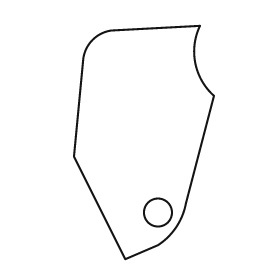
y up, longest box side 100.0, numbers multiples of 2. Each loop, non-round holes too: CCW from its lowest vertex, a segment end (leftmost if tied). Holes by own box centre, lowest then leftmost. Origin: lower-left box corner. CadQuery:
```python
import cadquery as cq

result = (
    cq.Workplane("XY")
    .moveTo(22.0, 0.0)
    .lineTo(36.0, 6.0)
    .threePointArc((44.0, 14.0), (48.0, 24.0))
    .lineTo(60.0, 70.0)
    .threePointArc((52.0, 84.0), (54.0, 100.0))
    .lineTo(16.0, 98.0)
    .threePointArc((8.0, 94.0), (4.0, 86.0))
    .lineTo(0.0, 44.0)
    .close()
    .moveTo(36.0, 20.0)
    .circle(6.0)
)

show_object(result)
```